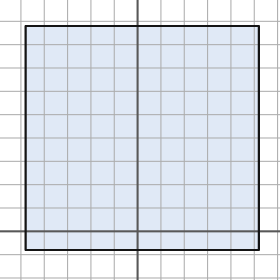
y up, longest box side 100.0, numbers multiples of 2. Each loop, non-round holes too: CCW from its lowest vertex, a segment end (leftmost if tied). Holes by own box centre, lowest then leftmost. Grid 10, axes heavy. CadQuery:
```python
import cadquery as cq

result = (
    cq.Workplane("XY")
    .moveTo(-48.0, -8.0)
    .lineTo(52.0, -8.0)
    .lineTo(52.0, 88.0)
    .lineTo(-48.0, 88.0)
    .close()
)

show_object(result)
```